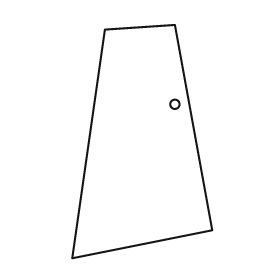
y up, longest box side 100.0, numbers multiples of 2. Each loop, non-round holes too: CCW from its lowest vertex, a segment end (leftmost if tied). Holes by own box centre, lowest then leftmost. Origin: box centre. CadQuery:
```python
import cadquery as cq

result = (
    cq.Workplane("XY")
    .moveTo(-30.0, -50.0)
    .lineTo(30.0, -38.0)
    .lineTo(14.0, 50.0)
    .lineTo(-16.0, 48.0)
    .close()
    .moveTo(14.0, 16.0)
    .circle(2.0)
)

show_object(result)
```